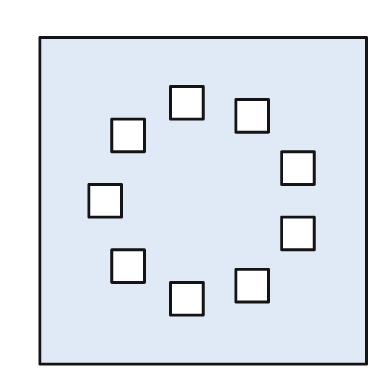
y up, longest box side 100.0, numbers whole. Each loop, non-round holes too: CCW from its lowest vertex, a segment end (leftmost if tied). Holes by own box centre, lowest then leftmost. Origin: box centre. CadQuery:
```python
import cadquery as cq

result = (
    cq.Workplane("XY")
    .moveTo(-50.0, -50.0)
    .lineTo(50.0, -50.0)
    .lineTo(50.0, 50.0)
    .lineTo(-50.0, 50.0)
    .close()
    .moveTo(-10.0, -35.0)
    .lineTo(0.0, -35.0)
    .lineTo(0.0, -25.0)
    .lineTo(-10.0, -25.0)
    .close()
    .moveTo(10.0, -31.0)
    .lineTo(20.0, -31.0)
    .lineTo(20.0, -21.0)
    .lineTo(10.0, -21.0)
    .close()
    .moveTo(-28.0, -25.0)
    .lineTo(-18.0, -25.0)
    .lineTo(-18.0, -15.0)
    .lineTo(-28.0, -15.0)
    .close()
    .moveTo(24.0, -15.0)
    .lineTo(34.0, -15.0)
    .lineTo(34.0, -5.0)
    .lineTo(24.0, -5.0)
    .close()
    .moveTo(-35.0, -5.0)
    .lineTo(-25.0, -5.0)
    .lineTo(-25.0, 5.0)
    .lineTo(-35.0, 5.0)
    .close()
    .moveTo(24.0, 5.0)
    .lineTo(34.0, 5.0)
    .lineTo(34.0, 15.0)
    .lineTo(24.0, 15.0)
    .close()
    .moveTo(-28.0, 15.0)
    .lineTo(-18.0, 15.0)
    .lineTo(-18.0, 25.0)
    .lineTo(-28.0, 25.0)
    .close()
    .moveTo(10.0, 21.0)
    .lineTo(20.0, 21.0)
    .lineTo(20.0, 31.0)
    .lineTo(10.0, 31.0)
    .close()
    .moveTo(-10.0, 25.0)
    .lineTo(0.0, 25.0)
    .lineTo(0.0, 35.0)
    .lineTo(-10.0, 35.0)
    .close()
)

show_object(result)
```